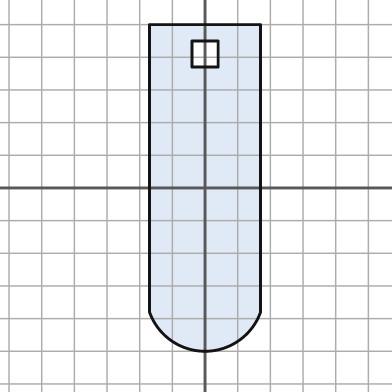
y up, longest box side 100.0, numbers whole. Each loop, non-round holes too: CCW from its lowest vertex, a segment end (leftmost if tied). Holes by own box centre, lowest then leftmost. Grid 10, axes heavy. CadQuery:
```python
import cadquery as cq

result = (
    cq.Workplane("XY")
    .moveTo(-17.0, -38.0)
    .threePointArc((0.0, -50.0), (17.0, -38.0))
    .lineTo(17.0, 50.0)
    .lineTo(-17.0, 50.0)
    .close()
    .moveTo(-4.0, 37.0)
    .lineTo(4.0, 37.0)
    .lineTo(4.0, 45.0)
    .lineTo(-4.0, 45.0)
    .close()
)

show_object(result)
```